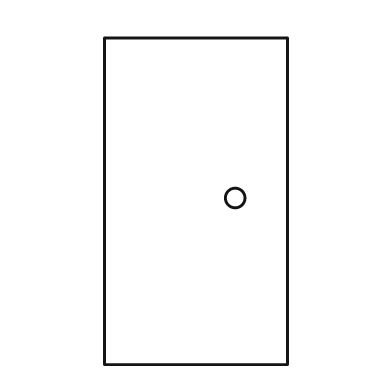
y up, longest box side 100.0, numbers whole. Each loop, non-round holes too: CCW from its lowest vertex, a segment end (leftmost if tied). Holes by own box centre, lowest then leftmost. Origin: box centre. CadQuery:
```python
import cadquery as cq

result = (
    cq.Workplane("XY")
    .moveTo(-28.0, -50.0)
    .lineTo(28.0, -50.0)
    .lineTo(28.0, 50.0)
    .lineTo(-28.0, 50.0)
    .close()
    .moveTo(12.0, 1.0)
    .circle(3.0)
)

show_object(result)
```